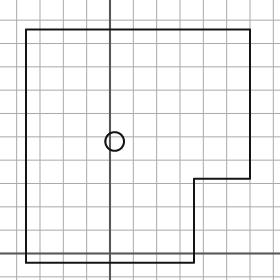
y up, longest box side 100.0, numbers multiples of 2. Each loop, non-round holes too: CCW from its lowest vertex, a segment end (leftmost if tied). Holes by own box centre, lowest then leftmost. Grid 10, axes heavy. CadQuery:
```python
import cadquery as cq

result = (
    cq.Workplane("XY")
    .moveTo(-36.0, -4.0)
    .lineTo(36.0, -4.0)
    .lineTo(36.0, 32.0)
    .lineTo(60.0, 32.0)
    .lineTo(60.0, 96.0)
    .lineTo(-36.0, 96.0)
    .close()
    .moveTo(2.0, 48.0)
    .circle(4.0)
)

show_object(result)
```